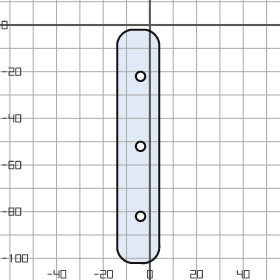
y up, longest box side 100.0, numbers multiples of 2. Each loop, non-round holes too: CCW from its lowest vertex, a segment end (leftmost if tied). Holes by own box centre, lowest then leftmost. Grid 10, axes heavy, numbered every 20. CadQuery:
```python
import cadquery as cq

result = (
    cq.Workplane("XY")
    .moveTo(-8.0, -102.0)
    .lineTo(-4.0, -102.0)
    .threePointArc((2.0, -100.0), (4.0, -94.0))
    .lineTo(4.0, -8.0)
    .threePointArc((2.0, -4.0), (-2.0, -2.0))
    .lineTo(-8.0, -2.0)
    .threePointArc((-12.0, -4.0), (-14.0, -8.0))
    .lineTo(-14.0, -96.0)
    .threePointArc((-12.0, -100.0), (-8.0, -102.0))
    .close()
    .moveTo(-4.0, -82.0)
    .circle(2.0)
    .moveTo(-4.0, -52.0)
    .circle(2.0)
    .moveTo(-4.0, -22.0)
    .circle(2.0)
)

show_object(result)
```